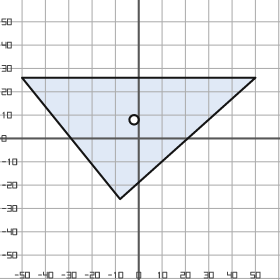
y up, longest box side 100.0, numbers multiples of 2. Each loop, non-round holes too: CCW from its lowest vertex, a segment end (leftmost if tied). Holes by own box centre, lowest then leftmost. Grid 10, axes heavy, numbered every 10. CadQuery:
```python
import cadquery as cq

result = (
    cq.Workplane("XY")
    .moveTo(-8.0, -26.0)
    .lineTo(50.0, 26.0)
    .lineTo(-50.0, 26.0)
    .close()
    .moveTo(-2.0, 8.0)
    .circle(2.0)
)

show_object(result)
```